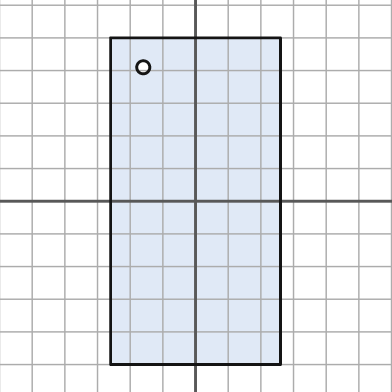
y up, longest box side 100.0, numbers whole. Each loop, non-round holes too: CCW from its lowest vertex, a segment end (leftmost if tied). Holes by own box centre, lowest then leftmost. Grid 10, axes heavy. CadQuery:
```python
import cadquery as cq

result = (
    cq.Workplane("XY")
    .moveTo(-26.0, -50.0)
    .lineTo(26.0, -50.0)
    .lineTo(26.0, 50.0)
    .lineTo(-26.0, 50.0)
    .close()
    .moveTo(-16.0, 41.0)
    .circle(2.0)
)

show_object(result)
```